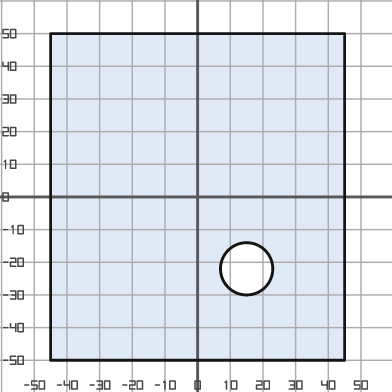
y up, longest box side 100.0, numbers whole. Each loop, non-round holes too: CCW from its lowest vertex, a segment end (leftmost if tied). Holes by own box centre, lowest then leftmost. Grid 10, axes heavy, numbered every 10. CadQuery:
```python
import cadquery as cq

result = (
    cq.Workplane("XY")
    .moveTo(-45.0, -50.0)
    .lineTo(45.0, -50.0)
    .lineTo(45.0, 50.0)
    .lineTo(-45.0, 50.0)
    .close()
    .moveTo(15.0, -22.0)
    .circle(8.0)
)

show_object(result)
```